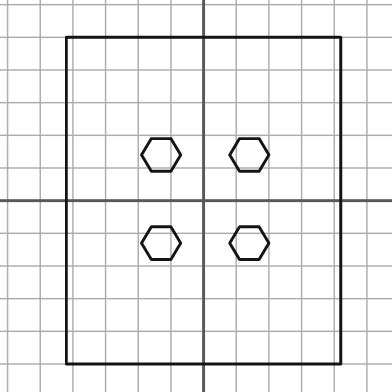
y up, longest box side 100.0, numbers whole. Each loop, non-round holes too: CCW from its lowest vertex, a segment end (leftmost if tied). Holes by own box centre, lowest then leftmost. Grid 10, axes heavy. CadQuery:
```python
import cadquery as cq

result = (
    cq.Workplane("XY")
    .moveTo(-42.0, -50.0)
    .lineTo(42.0, -50.0)
    .lineTo(42.0, 50.0)
    .lineTo(-42.0, 50.0)
    .close()
    .moveTo(-16.0, -18.0)
    .lineTo(-10.0, -18.0)
    .lineTo(-7.0, -13.0)
    .lineTo(-10.0, -8.0)
    .lineTo(-16.0, -8.0)
    .lineTo(-19.0, -13.0)
    .close()
    .moveTo(11.0, -18.0)
    .lineTo(17.0, -18.0)
    .lineTo(20.0, -13.0)
    .lineTo(17.0, -8.0)
    .lineTo(11.0, -8.0)
    .lineTo(8.0, -13.0)
    .close()
    .moveTo(-16.0, 9.0)
    .lineTo(-10.0, 9.0)
    .lineTo(-7.0, 14.0)
    .lineTo(-10.0, 19.0)
    .lineTo(-16.0, 19.0)
    .lineTo(-19.0, 14.0)
    .close()
    .moveTo(11.0, 9.0)
    .lineTo(17.0, 9.0)
    .lineTo(20.0, 14.0)
    .lineTo(17.0, 19.0)
    .lineTo(11.0, 19.0)
    .lineTo(8.0, 14.0)
    .close()
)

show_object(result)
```